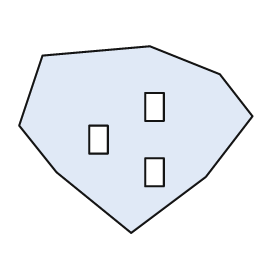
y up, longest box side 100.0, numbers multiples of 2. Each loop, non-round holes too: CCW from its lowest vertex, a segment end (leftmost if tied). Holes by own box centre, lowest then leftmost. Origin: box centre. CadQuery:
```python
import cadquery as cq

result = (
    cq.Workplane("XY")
    .moveTo(-2.0, -40.0)
    .lineTo(30.0, -16.0)
    .lineTo(50.0, 10.0)
    .lineTo(36.0, 28.0)
    .lineTo(6.0, 40.0)
    .lineTo(-40.0, 36.0)
    .lineTo(-50.0, 6.0)
    .lineTo(-34.0, -14.0)
    .close()
    .moveTo(4.0, -20.0)
    .lineTo(12.0, -20.0)
    .lineTo(12.0, -8.0)
    .lineTo(4.0, -8.0)
    .close()
    .moveTo(-20.0, -6.0)
    .lineTo(-12.0, -6.0)
    .lineTo(-12.0, 6.0)
    .lineTo(-20.0, 6.0)
    .close()
    .moveTo(4.0, 8.0)
    .lineTo(12.0, 8.0)
    .lineTo(12.0, 20.0)
    .lineTo(4.0, 20.0)
    .close()
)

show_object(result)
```